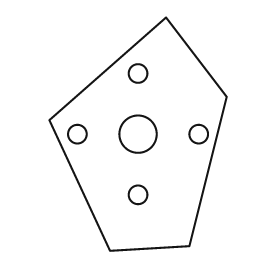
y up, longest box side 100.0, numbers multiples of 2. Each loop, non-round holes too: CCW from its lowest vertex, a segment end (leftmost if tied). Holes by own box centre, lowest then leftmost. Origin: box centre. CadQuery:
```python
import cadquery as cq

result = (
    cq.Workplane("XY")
    .moveTo(-12.0, -50.0)
    .lineTo(22.0, -48.0)
    .lineTo(38.0, 16.0)
    .lineTo(12.0, 50.0)
    .lineTo(-38.0, 6.0)
    .close()
    .moveTo(0.0, -26.0)
    .circle(4.0)
    .moveTo(-26.0, 0.0)
    .circle(4.0)
    .moveTo(0.0, 0.0)
    .circle(8.0)
    .moveTo(26.0, 0.0)
    .circle(4.0)
    .moveTo(0.0, 26.0)
    .circle(4.0)
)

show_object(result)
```